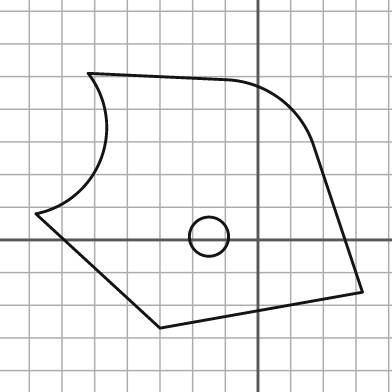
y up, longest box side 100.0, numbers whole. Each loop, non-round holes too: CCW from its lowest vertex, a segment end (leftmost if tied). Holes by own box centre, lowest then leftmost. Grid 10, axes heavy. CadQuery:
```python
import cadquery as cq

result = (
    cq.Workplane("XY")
    .moveTo(-30.0, -27.0)
    .lineTo(32.0, -16.0)
    .lineTo(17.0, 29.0)
    .threePointArc((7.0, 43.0), (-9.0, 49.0))
    .lineTo(-52.0, 51.0)
    .threePointArc((-48.0, 25.0), (-68.0, 8.0))
    .close()
    .moveTo(-15.0, 1.0)
    .circle(6.0)
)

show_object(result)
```